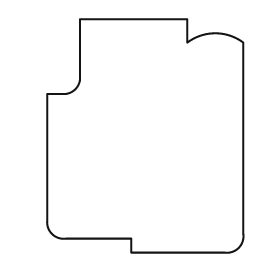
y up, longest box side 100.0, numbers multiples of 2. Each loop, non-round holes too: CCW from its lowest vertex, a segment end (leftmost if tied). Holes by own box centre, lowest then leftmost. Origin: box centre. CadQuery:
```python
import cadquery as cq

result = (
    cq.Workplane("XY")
    .moveTo(-6.0, -50.0)
    .lineTo(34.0, -50.0)
    .threePointArc((40.0, -48.0), (42.0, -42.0))
    .lineTo(42.0, 40.0)
    .threePointArc((30.0, 44.0), (18.0, 40.0))
    .lineTo(18.0, 50.0)
    .lineTo(-28.0, 50.0)
    .lineTo(-28.0, 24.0)
    .threePointArc((-30.0, 20.0), (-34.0, 18.0))
    .lineTo(-42.0, 18.0)
    .lineTo(-42.0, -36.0)
    .threePointArc((-40.0, -42.0), (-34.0, -44.0))
    .lineTo(-6.0, -44.0)
    .close()
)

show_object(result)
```